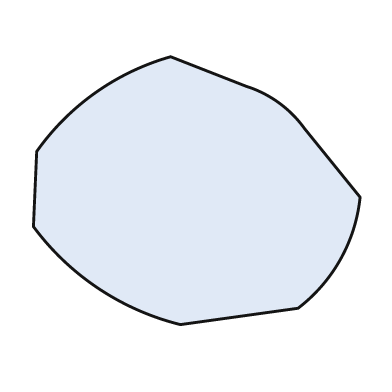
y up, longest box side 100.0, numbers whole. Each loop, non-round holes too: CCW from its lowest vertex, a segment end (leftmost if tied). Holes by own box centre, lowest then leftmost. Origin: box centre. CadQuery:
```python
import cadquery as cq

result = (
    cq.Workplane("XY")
    .moveTo(-5.0, -41.0)
    .lineTo(31.0, -36.0)
    .threePointArc((44.0, -21.0), (50.0, -2.0))
    .lineTo(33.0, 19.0)
    .threePointArc((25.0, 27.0), (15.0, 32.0))
    .lineTo(-8.0, 41.0)
    .threePointArc((-31.0, 30.0), (-49.0, 12.0))
    .lineTo(-50.0, -11.0)
    .threePointArc((-30.0, -30.0), (-5.0, -41.0))
    .close()
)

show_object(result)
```